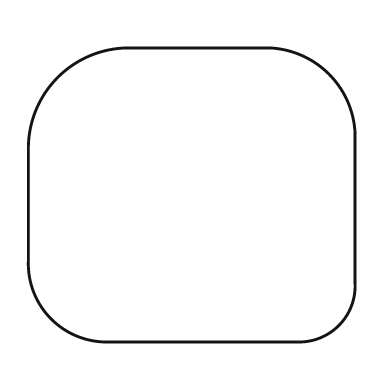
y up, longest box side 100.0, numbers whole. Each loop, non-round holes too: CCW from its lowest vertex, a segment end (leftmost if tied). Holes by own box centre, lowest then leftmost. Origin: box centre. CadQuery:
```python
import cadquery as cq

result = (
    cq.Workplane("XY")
    .moveTo(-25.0, -45.0)
    .lineTo(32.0, -45.0)
    .threePointArc((45.0, -40.0), (50.0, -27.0))
    .lineTo(50.0, 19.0)
    .threePointArc((42.0, 37.0), (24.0, 45.0))
    .lineTo(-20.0, 45.0)
    .threePointArc((-41.0, 36.0), (-50.0, 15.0))
    .lineTo(-50.0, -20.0)
    .threePointArc((-43.0, -38.0), (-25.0, -45.0))
    .close()
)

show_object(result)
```